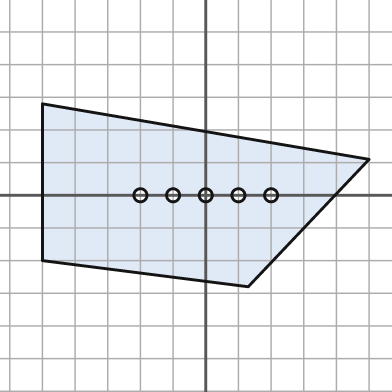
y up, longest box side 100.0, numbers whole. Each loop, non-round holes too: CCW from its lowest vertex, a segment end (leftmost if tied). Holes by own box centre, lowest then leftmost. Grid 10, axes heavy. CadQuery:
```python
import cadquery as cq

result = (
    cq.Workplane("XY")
    .moveTo(13.0, -28.0)
    .lineTo(50.0, 11.0)
    .lineTo(-50.0, 28.0)
    .lineTo(-50.0, -20.0)
    .close()
    .moveTo(-20.0, 0.0)
    .circle(2.0)
    .moveTo(-10.0, 0.0)
    .circle(2.0)
    .moveTo(0.0, 0.0)
    .circle(2.0)
    .moveTo(10.0, 0.0)
    .circle(2.0)
    .moveTo(20.0, 0.0)
    .circle(2.0)
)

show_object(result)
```